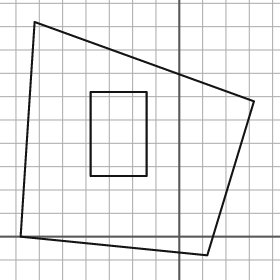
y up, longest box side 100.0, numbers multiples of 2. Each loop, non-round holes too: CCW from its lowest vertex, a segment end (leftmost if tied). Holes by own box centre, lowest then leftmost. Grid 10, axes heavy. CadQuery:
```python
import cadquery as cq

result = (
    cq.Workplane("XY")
    .moveTo(12.0, -8.0)
    .lineTo(32.0, 58.0)
    .lineTo(-62.0, 92.0)
    .lineTo(-68.0, 0.0)
    .close()
    .moveTo(-38.0, 26.0)
    .lineTo(-14.0, 26.0)
    .lineTo(-14.0, 62.0)
    .lineTo(-38.0, 62.0)
    .close()
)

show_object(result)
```